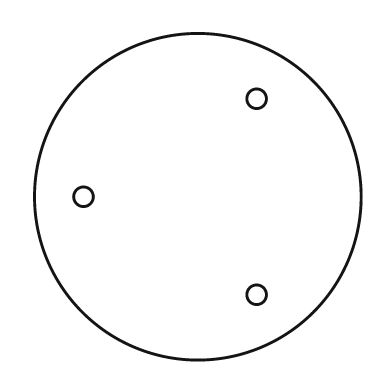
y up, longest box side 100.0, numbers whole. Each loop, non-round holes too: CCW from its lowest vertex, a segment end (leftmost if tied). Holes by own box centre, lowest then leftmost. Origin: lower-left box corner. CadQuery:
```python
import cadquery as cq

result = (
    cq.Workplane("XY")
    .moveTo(50.0, 50.0)
    .circle(50.0)
    .moveTo(68.0, 20.0)
    .circle(3.0)
    .moveTo(15.0, 50.0)
    .circle(3.0)
    .moveTo(68.0, 80.0)
    .circle(3.0)
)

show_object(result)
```